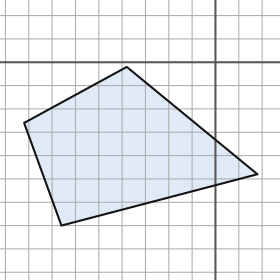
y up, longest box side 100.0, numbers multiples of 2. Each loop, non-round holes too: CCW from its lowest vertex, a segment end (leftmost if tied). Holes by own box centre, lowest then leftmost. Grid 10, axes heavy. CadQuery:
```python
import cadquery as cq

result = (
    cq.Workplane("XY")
    .moveTo(-66.0, -70.0)
    .lineTo(18.0, -48.0)
    .lineTo(-38.0, -2.0)
    .lineTo(-82.0, -26.0)
    .close()
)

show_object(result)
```